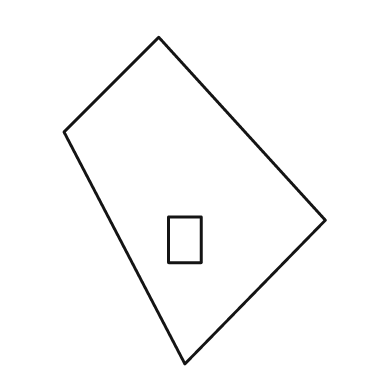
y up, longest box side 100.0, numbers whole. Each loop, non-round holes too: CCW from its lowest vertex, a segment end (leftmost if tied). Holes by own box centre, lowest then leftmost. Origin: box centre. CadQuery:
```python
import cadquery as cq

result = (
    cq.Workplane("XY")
    .moveTo(-3.0, -50.0)
    .lineTo(40.0, -6.0)
    .lineTo(-11.0, 50.0)
    .lineTo(-40.0, 21.0)
    .close()
    .moveTo(-8.0, -19.0)
    .lineTo(2.0, -19.0)
    .lineTo(2.0, -5.0)
    .lineTo(-8.0, -5.0)
    .close()
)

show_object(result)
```